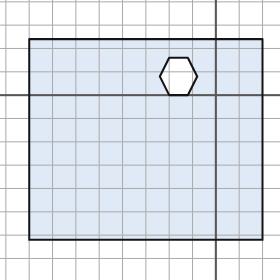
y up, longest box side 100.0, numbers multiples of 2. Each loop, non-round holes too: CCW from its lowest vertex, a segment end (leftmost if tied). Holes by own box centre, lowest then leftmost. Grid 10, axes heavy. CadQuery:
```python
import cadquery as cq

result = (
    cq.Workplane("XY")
    .moveTo(-80.0, -62.0)
    .lineTo(20.0, -62.0)
    .lineTo(20.0, 24.0)
    .lineTo(-80.0, 24.0)
    .close()
    .moveTo(-20.0, 0.0)
    .lineTo(-12.0, 0.0)
    .lineTo(-8.0, 8.0)
    .lineTo(-12.0, 16.0)
    .lineTo(-20.0, 16.0)
    .lineTo(-24.0, 8.0)
    .close()
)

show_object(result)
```